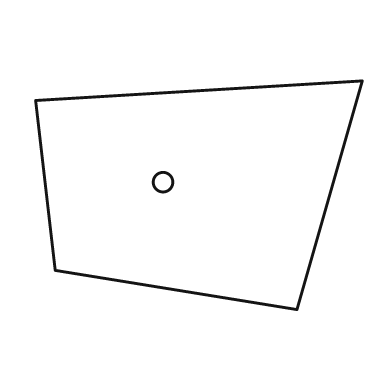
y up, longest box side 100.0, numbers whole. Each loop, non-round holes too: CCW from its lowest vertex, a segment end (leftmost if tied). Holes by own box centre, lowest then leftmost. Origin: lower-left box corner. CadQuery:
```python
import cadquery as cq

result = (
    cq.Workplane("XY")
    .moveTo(80.0, 0.0)
    .lineTo(100.0, 70.0)
    .lineTo(0.0, 64.0)
    .lineTo(6.0, 12.0)
    .close()
    .moveTo(39.0, 39.0)
    .circle(3.0)
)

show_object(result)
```